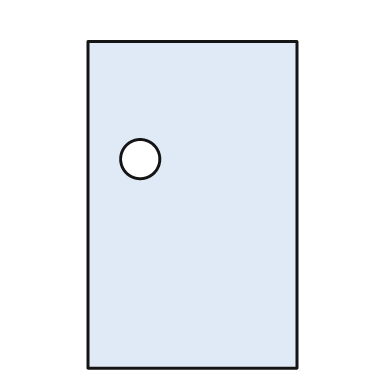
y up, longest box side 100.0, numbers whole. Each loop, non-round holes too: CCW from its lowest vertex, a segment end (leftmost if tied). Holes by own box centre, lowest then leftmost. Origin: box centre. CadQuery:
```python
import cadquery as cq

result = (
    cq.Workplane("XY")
    .moveTo(-32.0, -50.0)
    .lineTo(32.0, -50.0)
    .lineTo(32.0, 50.0)
    .lineTo(-32.0, 50.0)
    .close()
    .moveTo(-16.0, 14.0)
    .circle(6.0)
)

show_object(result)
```